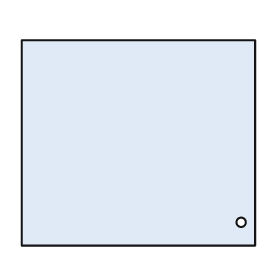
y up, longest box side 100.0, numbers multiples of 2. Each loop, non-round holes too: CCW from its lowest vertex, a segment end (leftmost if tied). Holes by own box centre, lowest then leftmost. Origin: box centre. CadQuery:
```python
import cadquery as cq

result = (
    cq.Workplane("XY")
    .moveTo(-50.0, -44.0)
    .lineTo(50.0, -44.0)
    .lineTo(50.0, 44.0)
    .lineTo(-50.0, 44.0)
    .close()
    .moveTo(44.0, -34.0)
    .circle(2.0)
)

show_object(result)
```